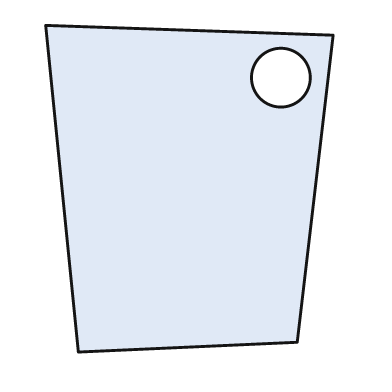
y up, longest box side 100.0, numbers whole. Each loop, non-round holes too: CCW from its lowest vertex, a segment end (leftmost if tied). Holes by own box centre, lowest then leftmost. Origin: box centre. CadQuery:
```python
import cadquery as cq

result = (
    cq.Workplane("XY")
    .moveTo(-34.0, -50.0)
    .lineTo(33.0, -47.0)
    .lineTo(44.0, 47.0)
    .lineTo(-44.0, 50.0)
    .close()
    .moveTo(28.0, 34.0)
    .circle(9.0)
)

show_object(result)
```